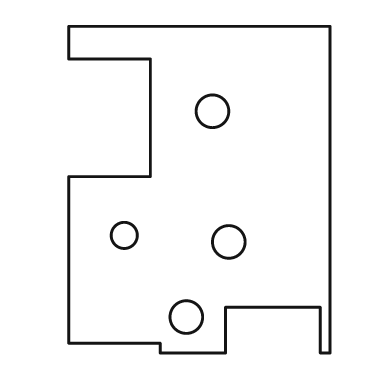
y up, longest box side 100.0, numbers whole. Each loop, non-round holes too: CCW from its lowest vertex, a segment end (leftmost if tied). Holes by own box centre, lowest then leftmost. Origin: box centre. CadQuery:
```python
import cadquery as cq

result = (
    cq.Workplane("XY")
    .moveTo(-12.0, -50.0)
    .lineTo(8.0, -50.0)
    .lineTo(8.0, -36.0)
    .lineTo(37.0, -36.0)
    .lineTo(37.0, -50.0)
    .lineTo(40.0, -50.0)
    .lineTo(40.0, 50.0)
    .lineTo(-40.0, 50.0)
    .lineTo(-40.0, 40.0)
    .lineTo(-15.0, 40.0)
    .lineTo(-15.0, 4.0)
    .lineTo(-40.0, 4.0)
    .lineTo(-40.0, -47.0)
    .lineTo(-12.0, -47.0)
    .close()
    .moveTo(-4.0, -39.0)
    .circle(5.0)
    .moveTo(9.0, -16.0)
    .circle(5.0)
    .moveTo(-23.0, -14.0)
    .circle(4.0)
    .moveTo(4.0, 24.0)
    .circle(5.0)
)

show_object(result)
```